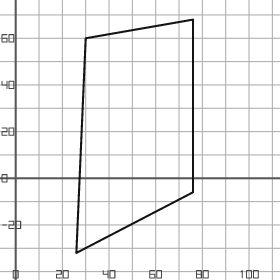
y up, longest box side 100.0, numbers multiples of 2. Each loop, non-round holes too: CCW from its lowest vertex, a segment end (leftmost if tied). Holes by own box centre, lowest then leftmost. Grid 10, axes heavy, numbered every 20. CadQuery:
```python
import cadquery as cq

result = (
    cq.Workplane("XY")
    .moveTo(26.0, -32.0)
    .lineTo(76.0, -6.0)
    .lineTo(76.0, 68.0)
    .lineTo(30.0, 60.0)
    .close()
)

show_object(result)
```